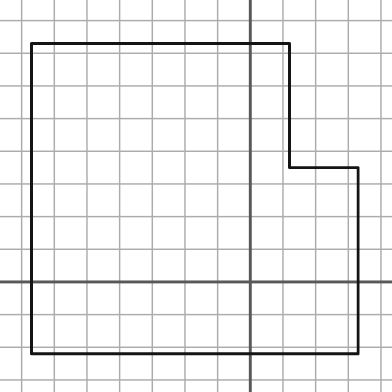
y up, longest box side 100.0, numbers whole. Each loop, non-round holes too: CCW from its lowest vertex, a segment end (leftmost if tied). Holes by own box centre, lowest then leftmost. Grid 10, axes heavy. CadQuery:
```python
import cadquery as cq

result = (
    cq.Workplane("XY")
    .moveTo(-67.0, -22.0)
    .lineTo(33.0, -22.0)
    .lineTo(33.0, 35.0)
    .lineTo(12.0, 35.0)
    .lineTo(12.0, 73.0)
    .lineTo(-67.0, 73.0)
    .close()
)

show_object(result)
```